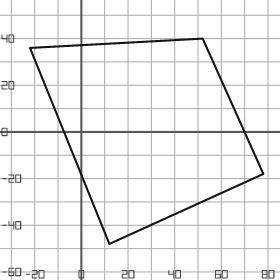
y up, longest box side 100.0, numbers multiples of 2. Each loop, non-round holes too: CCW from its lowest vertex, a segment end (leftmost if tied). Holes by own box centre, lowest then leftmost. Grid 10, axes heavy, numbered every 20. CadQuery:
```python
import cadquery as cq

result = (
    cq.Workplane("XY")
    .moveTo(12.0, -48.0)
    .lineTo(78.0, -18.0)
    .lineTo(52.0, 40.0)
    .lineTo(-22.0, 36.0)
    .close()
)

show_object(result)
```